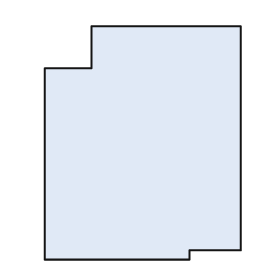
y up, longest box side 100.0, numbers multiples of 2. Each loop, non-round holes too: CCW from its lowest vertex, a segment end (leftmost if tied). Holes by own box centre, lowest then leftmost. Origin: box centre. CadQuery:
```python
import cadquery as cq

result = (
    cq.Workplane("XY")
    .moveTo(-42.0, -50.0)
    .lineTo(20.0, -50.0)
    .lineTo(20.0, -46.0)
    .lineTo(42.0, -46.0)
    .lineTo(42.0, 50.0)
    .lineTo(-22.0, 50.0)
    .lineTo(-22.0, 32.0)
    .lineTo(-42.0, 32.0)
    .close()
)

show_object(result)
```